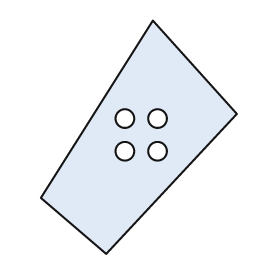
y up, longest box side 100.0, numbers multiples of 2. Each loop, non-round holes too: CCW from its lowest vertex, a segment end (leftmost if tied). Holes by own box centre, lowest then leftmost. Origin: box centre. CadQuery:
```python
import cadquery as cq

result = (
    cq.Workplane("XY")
    .moveTo(-14.0, -50.0)
    .lineTo(42.0, 10.0)
    .lineTo(6.0, 50.0)
    .lineTo(-42.0, -26.0)
    .close()
    .moveTo(-6.0, -6.0)
    .circle(4.0)
    .moveTo(8.0, -6.0)
    .circle(4.0)
    .moveTo(-6.0, 8.0)
    .circle(4.0)
    .moveTo(8.0, 8.0)
    .circle(4.0)
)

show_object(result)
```